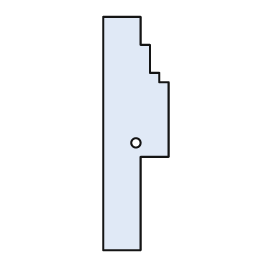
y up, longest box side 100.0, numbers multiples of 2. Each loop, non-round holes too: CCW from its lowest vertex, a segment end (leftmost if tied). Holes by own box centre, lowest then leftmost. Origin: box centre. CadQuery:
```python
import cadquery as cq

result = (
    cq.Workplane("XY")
    .moveTo(-14.0, -50.0)
    .lineTo(2.0, -50.0)
    .lineTo(2.0, -10.0)
    .lineTo(14.0, -10.0)
    .lineTo(14.0, 22.0)
    .lineTo(10.0, 22.0)
    .lineTo(10.0, 26.0)
    .lineTo(6.0, 26.0)
    .lineTo(6.0, 38.0)
    .lineTo(2.0, 38.0)
    .lineTo(2.0, 50.0)
    .lineTo(-14.0, 50.0)
    .close()
    .moveTo(0.0, -4.0)
    .circle(2.0)
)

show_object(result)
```